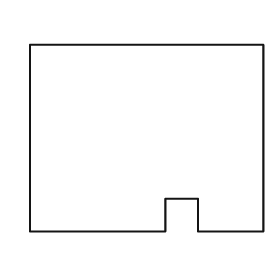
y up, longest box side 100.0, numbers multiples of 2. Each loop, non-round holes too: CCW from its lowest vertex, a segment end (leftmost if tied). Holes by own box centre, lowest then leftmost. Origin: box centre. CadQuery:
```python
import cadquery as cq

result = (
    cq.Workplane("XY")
    .moveTo(-50.0, -40.0)
    .lineTo(8.0, -40.0)
    .lineTo(8.0, -26.0)
    .lineTo(22.0, -26.0)
    .lineTo(22.0, -40.0)
    .lineTo(50.0, -40.0)
    .lineTo(50.0, 40.0)
    .lineTo(-50.0, 40.0)
    .close()
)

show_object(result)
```